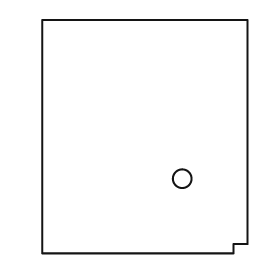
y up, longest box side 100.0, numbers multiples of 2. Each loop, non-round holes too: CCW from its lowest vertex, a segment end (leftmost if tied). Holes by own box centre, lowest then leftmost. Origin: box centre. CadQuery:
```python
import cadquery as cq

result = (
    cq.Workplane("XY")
    .moveTo(-44.0, -50.0)
    .lineTo(38.0, -50.0)
    .lineTo(38.0, -46.0)
    .lineTo(44.0, -46.0)
    .lineTo(44.0, 50.0)
    .lineTo(-44.0, 50.0)
    .close()
    .moveTo(16.0, -18.0)
    .circle(4.0)
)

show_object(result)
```